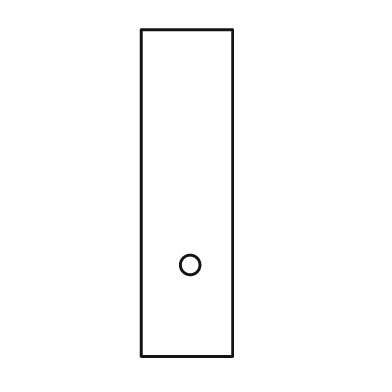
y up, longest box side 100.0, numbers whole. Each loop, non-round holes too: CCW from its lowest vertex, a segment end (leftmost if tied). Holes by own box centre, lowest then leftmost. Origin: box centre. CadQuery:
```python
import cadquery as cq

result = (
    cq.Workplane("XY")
    .moveTo(-14.0, -50.0)
    .lineTo(14.0, -50.0)
    .lineTo(14.0, 50.0)
    .lineTo(-14.0, 50.0)
    .close()
    .moveTo(1.0, -22.0)
    .circle(3.0)
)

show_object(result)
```